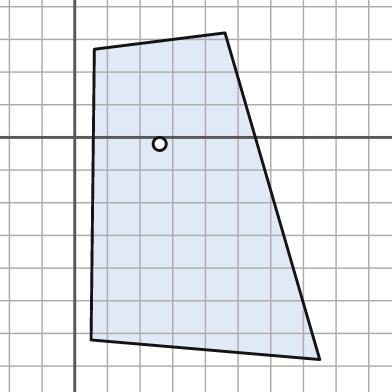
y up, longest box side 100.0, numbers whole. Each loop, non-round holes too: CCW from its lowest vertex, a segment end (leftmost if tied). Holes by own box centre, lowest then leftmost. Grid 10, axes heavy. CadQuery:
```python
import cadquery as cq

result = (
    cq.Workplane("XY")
    .moveTo(75.0, -68.0)
    .lineTo(46.0, 32.0)
    .lineTo(6.0, 27.0)
    .lineTo(5.0, -62.0)
    .close()
    .moveTo(26.0, -2.0)
    .circle(2.0)
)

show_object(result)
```